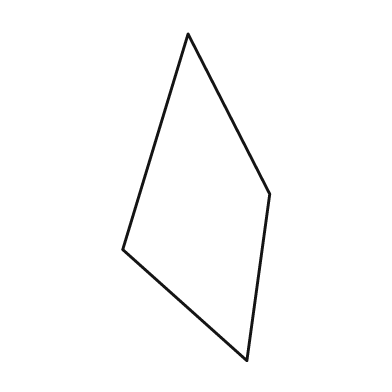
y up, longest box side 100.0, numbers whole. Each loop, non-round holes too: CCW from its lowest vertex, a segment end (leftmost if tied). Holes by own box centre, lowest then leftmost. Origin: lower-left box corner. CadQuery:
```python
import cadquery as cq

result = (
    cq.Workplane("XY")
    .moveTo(38.0, 0.0)
    .lineTo(45.0, 51.0)
    .lineTo(20.0, 100.0)
    .lineTo(0.0, 34.0)
    .close()
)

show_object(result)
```